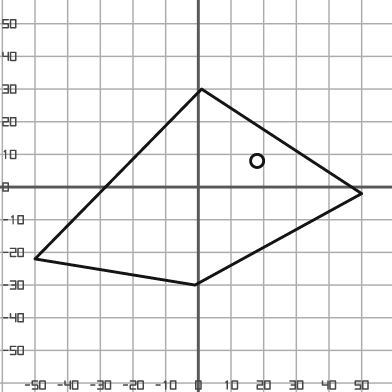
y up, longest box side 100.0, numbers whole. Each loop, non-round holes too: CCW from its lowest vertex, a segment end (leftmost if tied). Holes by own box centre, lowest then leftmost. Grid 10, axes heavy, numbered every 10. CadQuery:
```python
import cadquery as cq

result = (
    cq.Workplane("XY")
    .moveTo(-1.0, -30.0)
    .lineTo(50.0, -2.0)
    .lineTo(1.0, 30.0)
    .lineTo(-50.0, -22.0)
    .close()
    .moveTo(18.0, 8.0)
    .circle(2.0)
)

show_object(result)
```